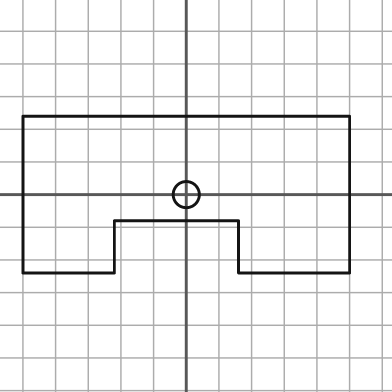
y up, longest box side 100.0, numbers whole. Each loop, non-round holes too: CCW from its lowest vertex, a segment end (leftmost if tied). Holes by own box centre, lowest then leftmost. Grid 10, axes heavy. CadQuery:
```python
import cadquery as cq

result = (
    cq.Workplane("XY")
    .moveTo(-50.0, -24.0)
    .lineTo(-22.0, -24.0)
    .lineTo(-22.0, -8.0)
    .lineTo(16.0, -8.0)
    .lineTo(16.0, -24.0)
    .lineTo(50.0, -24.0)
    .lineTo(50.0, 24.0)
    .lineTo(-50.0, 24.0)
    .close()
    .moveTo(0.0, 0.0)
    .circle(4.0)
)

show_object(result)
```